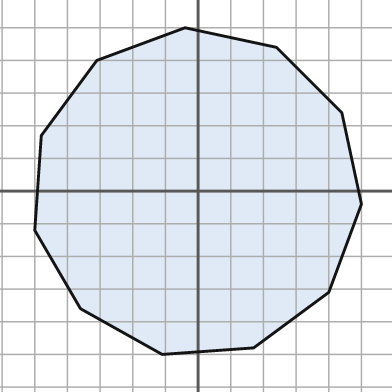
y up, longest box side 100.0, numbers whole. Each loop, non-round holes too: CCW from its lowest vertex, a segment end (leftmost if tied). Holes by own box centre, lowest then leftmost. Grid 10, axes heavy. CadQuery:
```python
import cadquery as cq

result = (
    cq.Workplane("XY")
    .moveTo(-11.0, -50.0)
    .lineTo(17.0, -48.0)
    .lineTo(40.0, -31.0)
    .lineTo(50.0, -4.0)
    .lineTo(44.0, 24.0)
    .lineTo(24.0, 44.0)
    .lineTo(-4.0, 50.0)
    .lineTo(-31.0, 40.0)
    .lineTo(-48.0, 17.0)
    .lineTo(-50.0, -12.0)
    .lineTo(-36.0, -36.0)
    .close()
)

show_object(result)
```